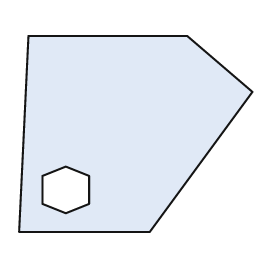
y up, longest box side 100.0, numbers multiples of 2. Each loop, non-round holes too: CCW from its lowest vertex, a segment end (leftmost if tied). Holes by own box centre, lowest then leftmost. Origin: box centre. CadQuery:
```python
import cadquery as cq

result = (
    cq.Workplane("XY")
    .moveTo(-50.0, -42.0)
    .lineTo(6.0, -42.0)
    .lineTo(50.0, 18.0)
    .lineTo(22.0, 42.0)
    .lineTo(-46.0, 42.0)
    .close()
    .moveTo(-30.0, -34.0)
    .lineTo(-20.0, -30.0)
    .lineTo(-20.0, -18.0)
    .lineTo(-30.0, -14.0)
    .lineTo(-40.0, -18.0)
    .lineTo(-40.0, -30.0)
    .close()
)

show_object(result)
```